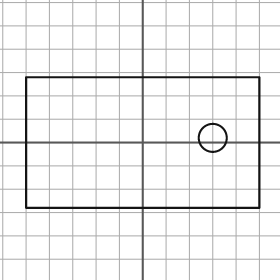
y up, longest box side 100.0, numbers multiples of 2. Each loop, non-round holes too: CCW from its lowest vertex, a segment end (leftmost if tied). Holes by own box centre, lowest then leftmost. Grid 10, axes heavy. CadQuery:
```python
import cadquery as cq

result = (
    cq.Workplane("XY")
    .moveTo(-50.0, -28.0)
    .lineTo(50.0, -28.0)
    .lineTo(50.0, 28.0)
    .lineTo(-50.0, 28.0)
    .close()
    .moveTo(30.0, 2.0)
    .circle(6.0)
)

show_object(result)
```